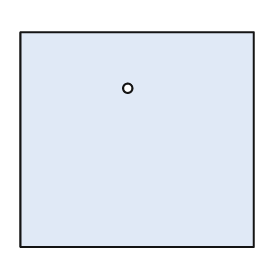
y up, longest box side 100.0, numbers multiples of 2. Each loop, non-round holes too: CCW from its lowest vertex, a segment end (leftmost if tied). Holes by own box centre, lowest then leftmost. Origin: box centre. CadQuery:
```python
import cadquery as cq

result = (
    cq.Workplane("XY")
    .moveTo(-50.0, -46.0)
    .lineTo(50.0, -46.0)
    .lineTo(50.0, 46.0)
    .lineTo(-50.0, 46.0)
    .close()
    .moveTo(-4.0, 22.0)
    .circle(2.0)
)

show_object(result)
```